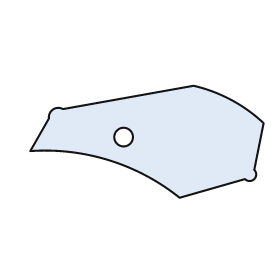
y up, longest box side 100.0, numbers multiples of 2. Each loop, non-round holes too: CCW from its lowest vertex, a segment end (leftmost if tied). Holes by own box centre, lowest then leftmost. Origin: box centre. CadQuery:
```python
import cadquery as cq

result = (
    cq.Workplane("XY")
    .moveTo(14.0, -24.0)
    .lineTo(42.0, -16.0)
    .threePointArc((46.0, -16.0), (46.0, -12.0))
    .lineTo(50.0, 8.0)
    .threePointArc((36.0, 18.0), (20.0, 24.0))
    .lineTo(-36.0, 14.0)
    .threePointArc((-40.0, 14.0), (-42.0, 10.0))
    .lineTo(-50.0, -4.0)
    .threePointArc((-16.0, -8.0), (14.0, -24.0))
    .close()
    .moveTo(-10.0, 2.0)
    .circle(4.0)
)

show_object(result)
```